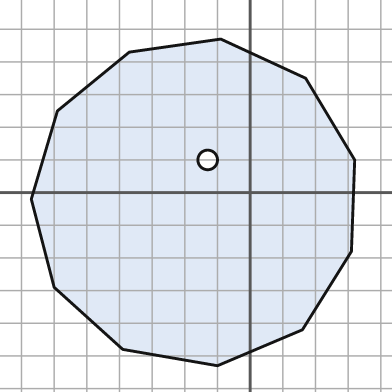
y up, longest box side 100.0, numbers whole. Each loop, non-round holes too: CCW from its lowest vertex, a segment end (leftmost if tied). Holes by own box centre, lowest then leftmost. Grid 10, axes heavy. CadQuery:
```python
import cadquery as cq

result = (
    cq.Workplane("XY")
    .moveTo(-10.0, -53.0)
    .lineTo(16.0, -42.0)
    .lineTo(31.0, -18.0)
    .lineTo(32.0, 10.0)
    .lineTo(17.0, 35.0)
    .lineTo(-9.0, 47.0)
    .lineTo(-37.0, 43.0)
    .lineTo(-59.0, 25.0)
    .lineTo(-67.0, -2.0)
    .lineTo(-60.0, -29.0)
    .lineTo(-39.0, -48.0)
    .close()
    .moveTo(-13.0, 10.0)
    .circle(3.0)
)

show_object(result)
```